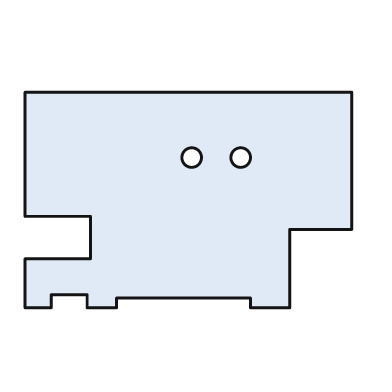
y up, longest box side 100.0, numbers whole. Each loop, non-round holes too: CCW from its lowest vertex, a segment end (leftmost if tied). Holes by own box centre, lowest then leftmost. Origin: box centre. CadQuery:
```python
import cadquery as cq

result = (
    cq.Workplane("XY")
    .moveTo(-50.0, -33.0)
    .lineTo(-42.0, -33.0)
    .lineTo(-42.0, -29.0)
    .lineTo(-31.0, -29.0)
    .lineTo(-31.0, -33.0)
    .lineTo(-22.0, -33.0)
    .lineTo(-22.0, -30.0)
    .lineTo(19.0, -30.0)
    .lineTo(19.0, -33.0)
    .lineTo(31.0, -33.0)
    .lineTo(31.0, -9.0)
    .lineTo(50.0, -9.0)
    .lineTo(50.0, 33.0)
    .lineTo(-50.0, 33.0)
    .lineTo(-50.0, -5.0)
    .lineTo(-30.0, -5.0)
    .lineTo(-30.0, -18.0)
    .lineTo(-50.0, -18.0)
    .close()
    .moveTo(1.0, 13.0)
    .circle(3.0)
    .moveTo(16.0, 13.0)
    .circle(3.0)
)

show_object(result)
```